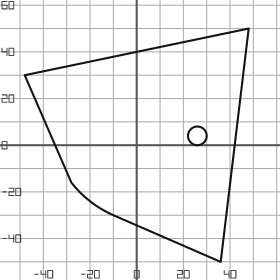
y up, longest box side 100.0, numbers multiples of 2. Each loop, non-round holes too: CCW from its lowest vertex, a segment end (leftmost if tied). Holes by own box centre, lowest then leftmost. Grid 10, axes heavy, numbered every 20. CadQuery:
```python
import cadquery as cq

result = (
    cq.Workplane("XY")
    .moveTo(36.0, -50.0)
    .lineTo(48.0, 50.0)
    .lineTo(-48.0, 30.0)
    .lineTo(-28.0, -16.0)
    .threePointArc((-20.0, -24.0), (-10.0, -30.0))
    .close()
    .moveTo(26.0, 4.0)
    .circle(4.0)
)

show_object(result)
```